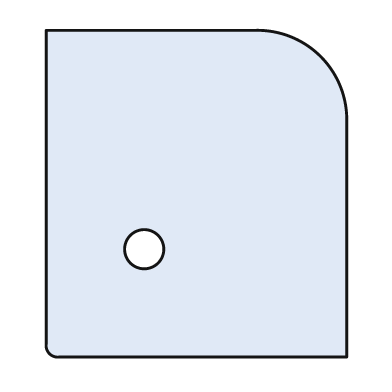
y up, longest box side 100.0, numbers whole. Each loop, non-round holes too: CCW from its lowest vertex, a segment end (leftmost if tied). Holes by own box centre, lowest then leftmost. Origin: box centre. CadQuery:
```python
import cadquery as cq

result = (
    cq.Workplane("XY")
    .moveTo(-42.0, -50.0)
    .lineTo(46.0, -50.0)
    .lineTo(46.0, 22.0)
    .threePointArc((38.0, 42.0), (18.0, 50.0))
    .lineTo(-46.0, 50.0)
    .lineTo(-46.0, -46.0)
    .threePointArc((-45.0, -49.0), (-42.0, -50.0))
    .close()
    .moveTo(-16.0, -17.0)
    .circle(6.0)
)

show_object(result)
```